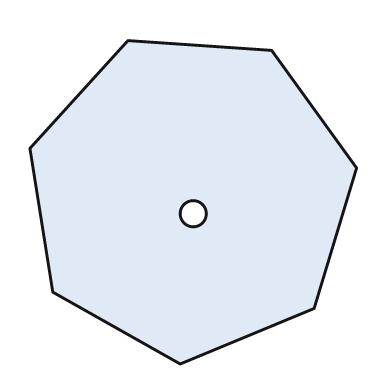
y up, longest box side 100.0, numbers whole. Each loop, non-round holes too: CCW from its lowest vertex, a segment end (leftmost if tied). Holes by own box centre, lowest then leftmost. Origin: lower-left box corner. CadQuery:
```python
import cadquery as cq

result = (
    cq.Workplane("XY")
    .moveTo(46.0, 0.0)
    .lineTo(87.0, 17.0)
    .lineTo(100.0, 60.0)
    .lineTo(74.0, 96.0)
    .lineTo(30.0, 99.0)
    .lineTo(0.0, 66.0)
    .lineTo(7.0, 22.0)
    .close()
    .moveTo(50.0, 46.0)
    .circle(4.0)
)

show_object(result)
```